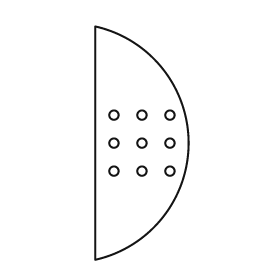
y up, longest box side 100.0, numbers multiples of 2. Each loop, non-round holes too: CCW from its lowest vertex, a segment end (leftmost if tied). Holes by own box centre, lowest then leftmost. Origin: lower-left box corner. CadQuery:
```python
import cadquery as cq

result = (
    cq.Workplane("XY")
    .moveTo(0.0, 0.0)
    .threePointArc((40.0, 50.0), (0.0, 100.0))
    .close()
    .moveTo(8.0, 38.0)
    .circle(2.0)
    .moveTo(20.0, 38.0)
    .circle(2.0)
    .moveTo(32.0, 38.0)
    .circle(2.0)
    .moveTo(8.0, 50.0)
    .circle(2.0)
    .moveTo(20.0, 50.0)
    .circle(2.0)
    .moveTo(32.0, 50.0)
    .circle(2.0)
    .moveTo(8.0, 62.0)
    .circle(2.0)
    .moveTo(20.0, 62.0)
    .circle(2.0)
    .moveTo(32.0, 62.0)
    .circle(2.0)
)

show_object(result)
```